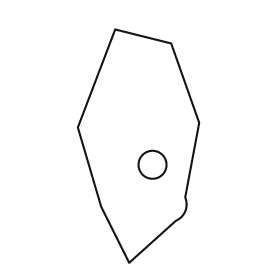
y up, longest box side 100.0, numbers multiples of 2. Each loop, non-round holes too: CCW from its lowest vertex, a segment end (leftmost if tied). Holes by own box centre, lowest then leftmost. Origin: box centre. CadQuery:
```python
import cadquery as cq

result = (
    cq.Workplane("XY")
    .moveTo(-4.0, -50.0)
    .lineTo(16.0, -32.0)
    .threePointArc((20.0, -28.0), (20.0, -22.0))
    .lineTo(26.0, 10.0)
    .lineTo(14.0, 44.0)
    .lineTo(-10.0, 50.0)
    .lineTo(-26.0, 8.0)
    .lineTo(-16.0, -26.0)
    .close()
    .moveTo(6.0, -8.0)
    .circle(6.0)
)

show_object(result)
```